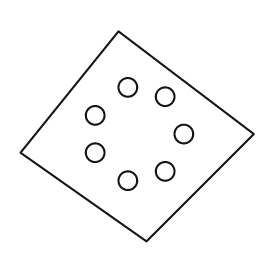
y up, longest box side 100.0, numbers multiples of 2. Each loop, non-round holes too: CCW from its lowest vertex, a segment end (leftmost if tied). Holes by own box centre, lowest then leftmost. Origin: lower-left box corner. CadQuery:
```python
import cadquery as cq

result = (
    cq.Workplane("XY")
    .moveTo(54.0, 0.0)
    .lineTo(100.0, 46.0)
    .lineTo(42.0, 90.0)
    .lineTo(0.0, 38.0)
    .close()
    .moveTo(46.0, 26.0)
    .circle(4.0)
    .moveTo(62.0, 30.0)
    .circle(4.0)
    .moveTo(32.0, 38.0)
    .circle(4.0)
    .moveTo(70.0, 46.0)
    .circle(4.0)
    .moveTo(32.0, 54.0)
    .circle(4.0)
    .moveTo(62.0, 62.0)
    .circle(4.0)
    .moveTo(46.0, 66.0)
    .circle(4.0)
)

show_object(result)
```